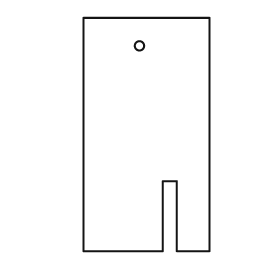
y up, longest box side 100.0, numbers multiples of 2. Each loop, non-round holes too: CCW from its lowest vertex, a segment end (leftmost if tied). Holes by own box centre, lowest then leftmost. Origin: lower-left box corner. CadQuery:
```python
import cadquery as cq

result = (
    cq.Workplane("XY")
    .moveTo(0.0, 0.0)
    .lineTo(34.0, 0.0)
    .lineTo(34.0, 30.0)
    .lineTo(40.0, 30.0)
    .lineTo(40.0, 0.0)
    .lineTo(54.0, 0.0)
    .lineTo(54.0, 100.0)
    .lineTo(0.0, 100.0)
    .close()
    .moveTo(24.0, 88.0)
    .circle(2.0)
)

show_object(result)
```